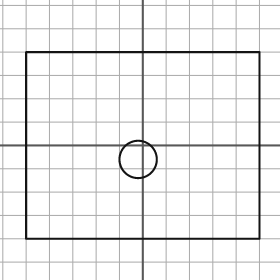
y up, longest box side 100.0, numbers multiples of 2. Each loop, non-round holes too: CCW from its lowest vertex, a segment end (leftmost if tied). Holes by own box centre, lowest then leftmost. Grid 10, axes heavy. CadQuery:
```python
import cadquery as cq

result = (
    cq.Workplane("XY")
    .moveTo(-50.0, -40.0)
    .lineTo(50.0, -40.0)
    .lineTo(50.0, 40.0)
    .lineTo(-50.0, 40.0)
    .close()
    .moveTo(-2.0, -6.0)
    .circle(8.0)
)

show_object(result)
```